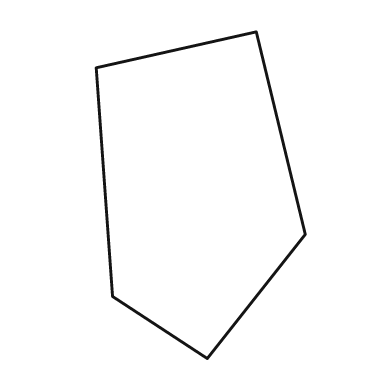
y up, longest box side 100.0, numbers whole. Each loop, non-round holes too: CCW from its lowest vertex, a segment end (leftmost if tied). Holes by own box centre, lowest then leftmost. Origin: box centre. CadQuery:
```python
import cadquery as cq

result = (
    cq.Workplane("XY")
    .moveTo(2.0, -50.0)
    .lineTo(32.0, -12.0)
    .lineTo(17.0, 50.0)
    .lineTo(-32.0, 39.0)
    .lineTo(-27.0, -31.0)
    .close()
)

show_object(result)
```